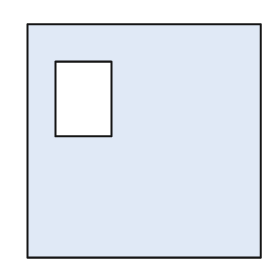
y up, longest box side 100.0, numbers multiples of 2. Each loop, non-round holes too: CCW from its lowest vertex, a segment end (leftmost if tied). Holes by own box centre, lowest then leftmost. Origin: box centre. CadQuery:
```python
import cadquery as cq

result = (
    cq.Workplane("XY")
    .moveTo(-50.0, -50.0)
    .lineTo(50.0, -50.0)
    .lineTo(50.0, 50.0)
    .lineTo(-50.0, 50.0)
    .close()
    .moveTo(-38.0, 2.0)
    .lineTo(-14.0, 2.0)
    .lineTo(-14.0, 34.0)
    .lineTo(-38.0, 34.0)
    .close()
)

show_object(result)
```